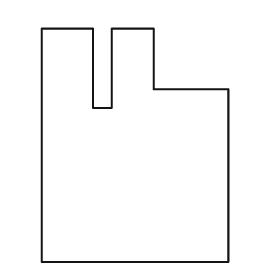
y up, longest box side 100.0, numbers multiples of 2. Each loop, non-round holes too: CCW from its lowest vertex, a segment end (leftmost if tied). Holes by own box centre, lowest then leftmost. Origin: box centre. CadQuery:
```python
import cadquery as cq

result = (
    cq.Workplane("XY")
    .moveTo(-40.0, -50.0)
    .lineTo(40.0, -50.0)
    .lineTo(40.0, 24.0)
    .lineTo(8.0, 24.0)
    .lineTo(8.0, 50.0)
    .lineTo(-10.0, 50.0)
    .lineTo(-10.0, 16.0)
    .lineTo(-18.0, 16.0)
    .lineTo(-18.0, 50.0)
    .lineTo(-40.0, 50.0)
    .close()
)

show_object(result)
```